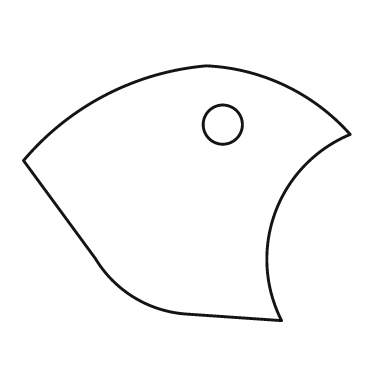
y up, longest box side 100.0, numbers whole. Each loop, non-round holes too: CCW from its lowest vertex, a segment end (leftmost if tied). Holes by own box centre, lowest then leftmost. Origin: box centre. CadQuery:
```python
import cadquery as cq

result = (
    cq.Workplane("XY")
    .moveTo(29.0, -39.0)
    .threePointArc((27.0, -6.0), (50.0, 18.0))
    .threePointArc((30.0, 33.0), (6.0, 39.0))
    .threePointArc((-25.0, 30.0), (-50.0, 10.0))
    .lineTo(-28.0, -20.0)
    .threePointArc((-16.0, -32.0), (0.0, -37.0))
    .close()
    .moveTo(11.0, 21.0)
    .circle(6.0)
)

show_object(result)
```